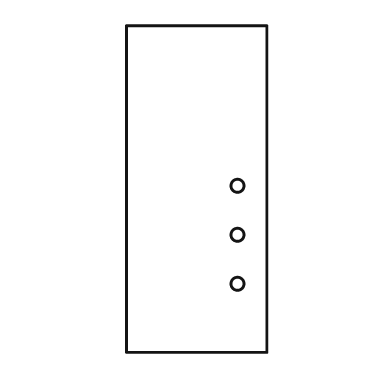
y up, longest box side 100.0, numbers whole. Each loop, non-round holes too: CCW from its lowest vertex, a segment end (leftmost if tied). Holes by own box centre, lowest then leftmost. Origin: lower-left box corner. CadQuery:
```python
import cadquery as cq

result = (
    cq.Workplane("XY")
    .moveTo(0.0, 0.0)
    .lineTo(43.0, 0.0)
    .lineTo(43.0, 100.0)
    .lineTo(0.0, 100.0)
    .close()
    .moveTo(34.0, 21.0)
    .circle(2.0)
    .moveTo(34.0, 36.0)
    .circle(2.0)
    .moveTo(34.0, 51.0)
    .circle(2.0)
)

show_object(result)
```